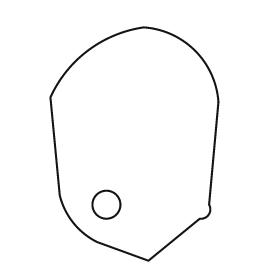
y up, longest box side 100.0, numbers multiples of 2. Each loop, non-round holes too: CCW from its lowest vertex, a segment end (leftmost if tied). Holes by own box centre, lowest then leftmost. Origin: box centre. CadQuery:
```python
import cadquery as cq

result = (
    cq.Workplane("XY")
    .moveTo(6.0, -50.0)
    .lineTo(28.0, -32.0)
    .threePointArc((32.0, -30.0), (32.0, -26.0))
    .lineTo(36.0, 18.0)
    .threePointArc((26.0, 40.0), (4.0, 50.0))
    .threePointArc((-20.0, 40.0), (-36.0, 20.0))
    .lineTo(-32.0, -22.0)
    .threePointArc((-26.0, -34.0), (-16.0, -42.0))
    .close()
    .moveTo(-12.0, -26.0)
    .circle(6.0)
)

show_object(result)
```